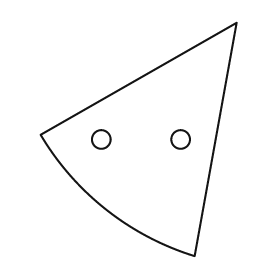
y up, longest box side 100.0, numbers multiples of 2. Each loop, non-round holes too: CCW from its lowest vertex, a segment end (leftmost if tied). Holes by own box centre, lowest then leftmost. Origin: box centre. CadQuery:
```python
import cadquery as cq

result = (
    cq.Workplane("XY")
    .moveTo(24.0, -50.0)
    .lineTo(42.0, 50.0)
    .lineTo(-42.0, 2.0)
    .threePointArc((-14.0, -30.0), (24.0, -50.0))
    .close()
    .moveTo(-16.0, 0.0)
    .circle(4.0)
    .moveTo(18.0, 0.0)
    .circle(4.0)
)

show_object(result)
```